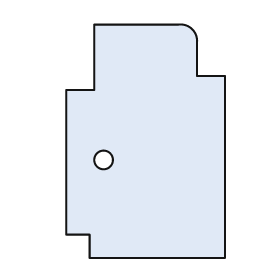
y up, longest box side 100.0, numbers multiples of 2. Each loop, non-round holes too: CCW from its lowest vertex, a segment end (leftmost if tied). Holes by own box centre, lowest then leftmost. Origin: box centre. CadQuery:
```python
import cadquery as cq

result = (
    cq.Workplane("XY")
    .moveTo(-24.0, -50.0)
    .lineTo(34.0, -50.0)
    .lineTo(34.0, 28.0)
    .lineTo(22.0, 28.0)
    .lineTo(22.0, 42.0)
    .threePointArc((20.0, 48.0), (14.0, 50.0))
    .lineTo(-22.0, 50.0)
    .lineTo(-22.0, 22.0)
    .lineTo(-34.0, 22.0)
    .lineTo(-34.0, -40.0)
    .lineTo(-24.0, -40.0)
    .close()
    .moveTo(-18.0, -8.0)
    .circle(4.0)
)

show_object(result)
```